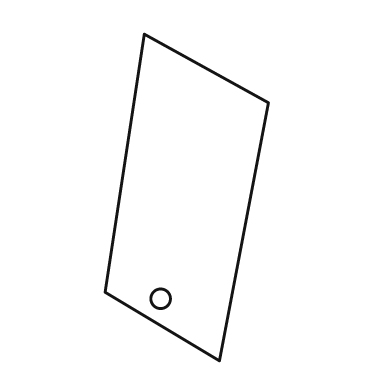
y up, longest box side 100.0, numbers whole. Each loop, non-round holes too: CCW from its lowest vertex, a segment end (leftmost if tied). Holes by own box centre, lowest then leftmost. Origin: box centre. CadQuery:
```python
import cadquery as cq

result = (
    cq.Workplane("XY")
    .moveTo(10.0, -50.0)
    .lineTo(25.0, 29.0)
    .lineTo(-13.0, 50.0)
    .lineTo(-25.0, -29.0)
    .close()
    .moveTo(-8.0, -31.0)
    .circle(3.0)
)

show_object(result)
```